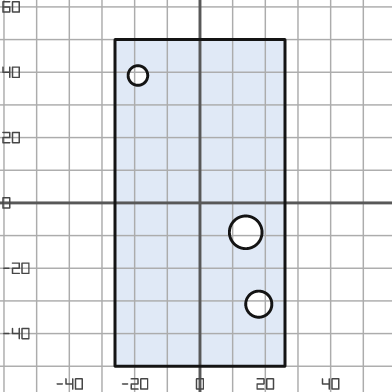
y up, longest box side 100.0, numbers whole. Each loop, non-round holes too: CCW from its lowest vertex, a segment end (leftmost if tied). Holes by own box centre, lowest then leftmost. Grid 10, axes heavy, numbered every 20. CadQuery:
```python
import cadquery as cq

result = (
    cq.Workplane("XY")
    .moveTo(-26.0, -50.0)
    .lineTo(26.0, -50.0)
    .lineTo(26.0, 50.0)
    .lineTo(-26.0, 50.0)
    .close()
    .moveTo(18.0, -31.0)
    .circle(4.0)
    .moveTo(14.0, -9.0)
    .circle(5.0)
    .moveTo(-19.0, 39.0)
    .circle(3.0)
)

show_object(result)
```